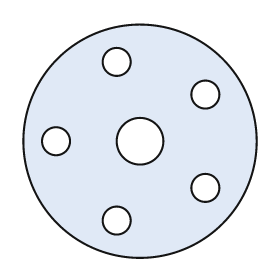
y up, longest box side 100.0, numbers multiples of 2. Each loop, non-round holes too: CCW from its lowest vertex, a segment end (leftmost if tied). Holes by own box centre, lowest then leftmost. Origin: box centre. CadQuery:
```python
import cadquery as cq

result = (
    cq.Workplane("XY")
    .moveTo(0.0, 0.0)
    .circle(50.0)
    .moveTo(-10.0, -34.0)
    .circle(6.0)
    .moveTo(28.0, -20.0)
    .circle(6.0)
    .moveTo(-36.0, 0.0)
    .circle(6.0)
    .moveTo(0.0, 0.0)
    .circle(10.0)
    .moveTo(28.0, 20.0)
    .circle(6.0)
    .moveTo(-10.0, 34.0)
    .circle(6.0)
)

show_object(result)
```